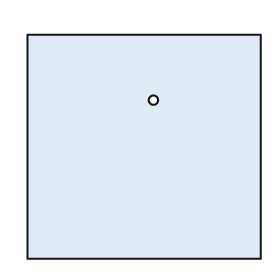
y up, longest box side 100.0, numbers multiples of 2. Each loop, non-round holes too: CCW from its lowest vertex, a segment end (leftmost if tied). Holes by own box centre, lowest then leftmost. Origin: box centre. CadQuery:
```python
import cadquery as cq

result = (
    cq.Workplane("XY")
    .moveTo(-50.0, -48.0)
    .lineTo(50.0, -48.0)
    .lineTo(50.0, 48.0)
    .lineTo(-50.0, 48.0)
    .close()
    .moveTo(4.0, 20.0)
    .circle(2.0)
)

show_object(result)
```